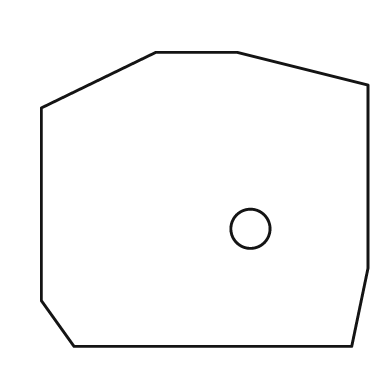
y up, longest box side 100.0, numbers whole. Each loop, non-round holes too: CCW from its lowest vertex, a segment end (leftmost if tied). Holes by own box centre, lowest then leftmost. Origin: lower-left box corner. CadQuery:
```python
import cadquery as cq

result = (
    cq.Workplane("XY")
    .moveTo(10.0, 0.0)
    .lineTo(95.0, 0.0)
    .lineTo(100.0, 24.0)
    .lineTo(100.0, 80.0)
    .lineTo(60.0, 90.0)
    .lineTo(35.0, 90.0)
    .lineTo(0.0, 73.0)
    .lineTo(0.0, 14.0)
    .close()
    .moveTo(64.0, 36.0)
    .circle(6.0)
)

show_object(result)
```